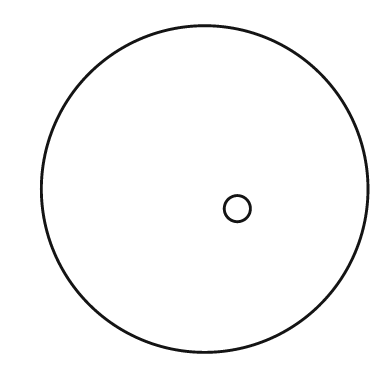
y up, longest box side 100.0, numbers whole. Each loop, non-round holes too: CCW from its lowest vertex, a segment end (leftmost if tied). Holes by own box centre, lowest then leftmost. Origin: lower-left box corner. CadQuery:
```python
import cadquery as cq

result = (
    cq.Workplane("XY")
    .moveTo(50.0, 50.0)
    .circle(50.0)
    .moveTo(60.0, 44.0)
    .circle(4.0)
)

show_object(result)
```